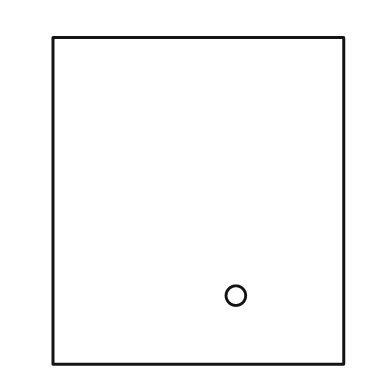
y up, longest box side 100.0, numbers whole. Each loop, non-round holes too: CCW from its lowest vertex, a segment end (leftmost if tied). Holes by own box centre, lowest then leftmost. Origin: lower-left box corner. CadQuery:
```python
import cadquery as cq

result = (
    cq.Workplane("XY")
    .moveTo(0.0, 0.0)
    .lineTo(89.0, 0.0)
    .lineTo(89.0, 100.0)
    .lineTo(0.0, 100.0)
    .close()
    .moveTo(56.0, 21.0)
    .circle(3.0)
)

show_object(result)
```